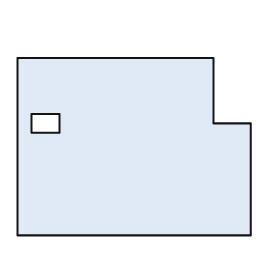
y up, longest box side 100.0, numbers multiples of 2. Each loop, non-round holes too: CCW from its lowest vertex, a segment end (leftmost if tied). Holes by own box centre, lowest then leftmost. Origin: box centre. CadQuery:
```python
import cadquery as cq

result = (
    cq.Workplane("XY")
    .moveTo(-50.0, -38.0)
    .lineTo(50.0, -38.0)
    .lineTo(50.0, 10.0)
    .lineTo(34.0, 10.0)
    .lineTo(34.0, 38.0)
    .lineTo(-50.0, 38.0)
    .close()
    .moveTo(-44.0, 6.0)
    .lineTo(-32.0, 6.0)
    .lineTo(-32.0, 14.0)
    .lineTo(-44.0, 14.0)
    .close()
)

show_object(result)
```